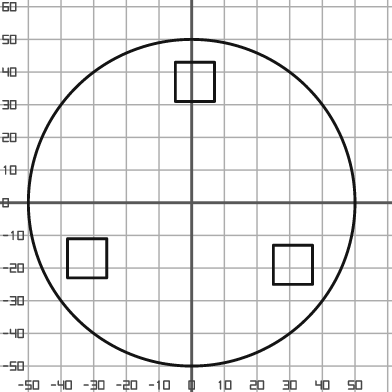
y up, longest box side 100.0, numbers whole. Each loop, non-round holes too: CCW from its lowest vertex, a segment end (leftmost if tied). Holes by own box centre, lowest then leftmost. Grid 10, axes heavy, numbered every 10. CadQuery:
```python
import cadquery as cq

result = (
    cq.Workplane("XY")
    .moveTo(0.0, 0.0)
    .circle(50.0)
    .moveTo(25.0, -25.0)
    .lineTo(37.0, -25.0)
    .lineTo(37.0, -13.0)
    .lineTo(25.0, -13.0)
    .close()
    .moveTo(-38.0, -23.0)
    .lineTo(-26.0, -23.0)
    .lineTo(-26.0, -11.0)
    .lineTo(-38.0, -11.0)
    .close()
    .moveTo(-5.0, 31.0)
    .lineTo(7.0, 31.0)
    .lineTo(7.0, 43.0)
    .lineTo(-5.0, 43.0)
    .close()
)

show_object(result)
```